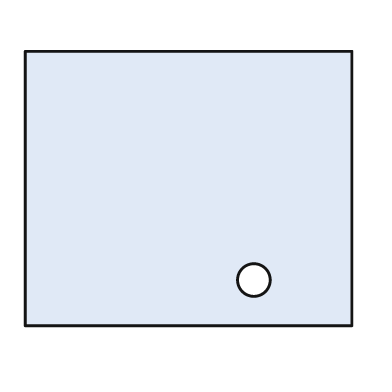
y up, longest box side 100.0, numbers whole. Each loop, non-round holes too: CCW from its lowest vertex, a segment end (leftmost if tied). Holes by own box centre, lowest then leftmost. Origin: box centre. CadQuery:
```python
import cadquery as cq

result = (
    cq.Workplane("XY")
    .moveTo(-50.0, -42.0)
    .lineTo(50.0, -42.0)
    .lineTo(50.0, 42.0)
    .lineTo(-50.0, 42.0)
    .close()
    .moveTo(20.0, -28.0)
    .circle(5.0)
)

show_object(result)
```